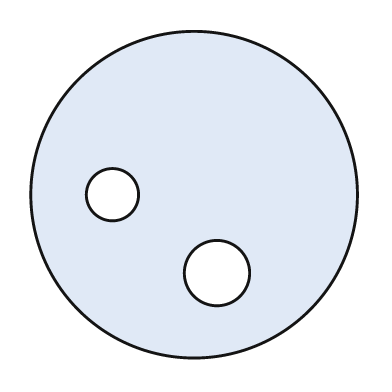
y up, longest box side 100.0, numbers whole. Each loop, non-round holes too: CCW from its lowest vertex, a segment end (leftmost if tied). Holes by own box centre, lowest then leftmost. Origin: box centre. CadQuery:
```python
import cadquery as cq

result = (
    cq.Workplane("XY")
    .moveTo(0.0, 0.0)
    .circle(50.0)
    .moveTo(7.0, -24.0)
    .circle(10.0)
    .moveTo(-25.0, 0.0)
    .circle(8.0)
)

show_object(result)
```